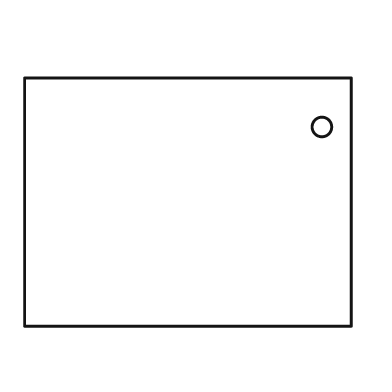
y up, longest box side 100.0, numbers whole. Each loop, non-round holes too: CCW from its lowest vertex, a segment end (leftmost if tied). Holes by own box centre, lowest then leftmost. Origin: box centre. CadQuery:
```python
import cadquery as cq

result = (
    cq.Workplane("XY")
    .moveTo(-50.0, -38.0)
    .lineTo(50.0, -38.0)
    .lineTo(50.0, 38.0)
    .lineTo(-50.0, 38.0)
    .close()
    .moveTo(41.0, 23.0)
    .circle(3.0)
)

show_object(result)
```